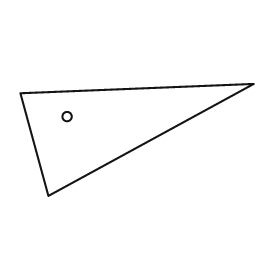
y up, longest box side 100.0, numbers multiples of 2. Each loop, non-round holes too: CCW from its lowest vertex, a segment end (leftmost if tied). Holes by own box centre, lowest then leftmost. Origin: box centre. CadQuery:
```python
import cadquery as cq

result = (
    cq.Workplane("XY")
    .moveTo(-38.0, -24.0)
    .lineTo(50.0, 24.0)
    .lineTo(-50.0, 20.0)
    .close()
    .moveTo(-30.0, 10.0)
    .circle(2.0)
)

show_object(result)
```